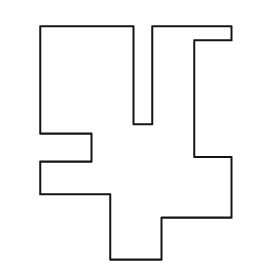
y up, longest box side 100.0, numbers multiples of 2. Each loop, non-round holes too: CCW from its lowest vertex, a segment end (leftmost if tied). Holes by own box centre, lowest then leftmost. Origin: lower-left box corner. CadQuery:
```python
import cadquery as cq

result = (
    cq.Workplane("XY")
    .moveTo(30.0, 0.0)
    .lineTo(52.0, 0.0)
    .lineTo(52.0, 18.0)
    .lineTo(82.0, 18.0)
    .lineTo(82.0, 44.0)
    .lineTo(66.0, 44.0)
    .lineTo(66.0, 94.0)
    .lineTo(82.0, 94.0)
    .lineTo(82.0, 100.0)
    .lineTo(48.0, 100.0)
    .lineTo(48.0, 58.0)
    .lineTo(40.0, 58.0)
    .lineTo(40.0, 100.0)
    .lineTo(0.0, 100.0)
    .lineTo(0.0, 54.0)
    .lineTo(22.0, 54.0)
    .lineTo(22.0, 42.0)
    .lineTo(0.0, 42.0)
    .lineTo(0.0, 28.0)
    .lineTo(30.0, 28.0)
    .close()
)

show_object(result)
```